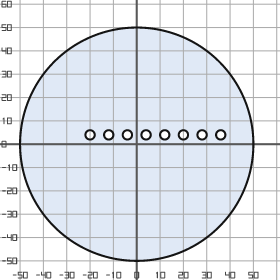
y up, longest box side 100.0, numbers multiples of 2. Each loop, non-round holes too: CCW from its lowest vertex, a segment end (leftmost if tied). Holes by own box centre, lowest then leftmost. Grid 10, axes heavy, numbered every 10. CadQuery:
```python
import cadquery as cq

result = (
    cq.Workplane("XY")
    .moveTo(0.0, 0.0)
    .circle(50.0)
    .moveTo(-20.0, 4.0)
    .circle(2.0)
    .moveTo(-12.0, 4.0)
    .circle(2.0)
    .moveTo(-4.0, 4.0)
    .circle(2.0)
    .moveTo(4.0, 4.0)
    .circle(2.0)
    .moveTo(12.0, 4.0)
    .circle(2.0)
    .moveTo(20.0, 4.0)
    .circle(2.0)
    .moveTo(28.0, 4.0)
    .circle(2.0)
    .moveTo(36.0, 4.0)
    .circle(2.0)
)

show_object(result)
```